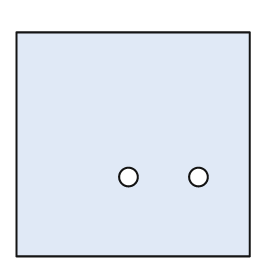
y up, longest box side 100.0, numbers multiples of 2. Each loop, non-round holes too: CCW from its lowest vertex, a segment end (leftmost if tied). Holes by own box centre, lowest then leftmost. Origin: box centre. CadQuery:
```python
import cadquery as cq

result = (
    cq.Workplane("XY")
    .moveTo(-50.0, -48.0)
    .lineTo(50.0, -48.0)
    .lineTo(50.0, 48.0)
    .lineTo(-50.0, 48.0)
    .close()
    .moveTo(-2.0, -14.0)
    .circle(4.0)
    .moveTo(28.0, -14.0)
    .circle(4.0)
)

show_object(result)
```